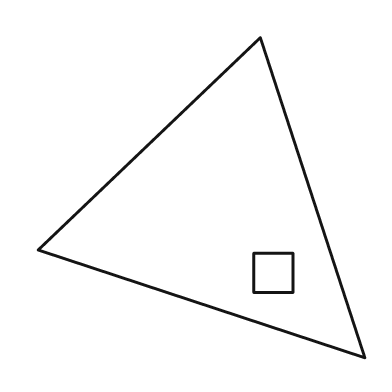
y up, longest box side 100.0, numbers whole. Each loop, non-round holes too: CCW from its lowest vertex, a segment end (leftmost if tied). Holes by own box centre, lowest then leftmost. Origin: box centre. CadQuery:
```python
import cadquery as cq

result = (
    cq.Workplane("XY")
    .moveTo(50.0, -49.0)
    .lineTo(18.0, 49.0)
    .lineTo(-50.0, -16.0)
    .close()
    .moveTo(16.0, -29.0)
    .lineTo(28.0, -29.0)
    .lineTo(28.0, -17.0)
    .lineTo(16.0, -17.0)
    .close()
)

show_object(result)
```